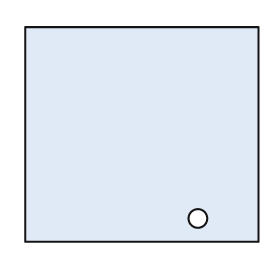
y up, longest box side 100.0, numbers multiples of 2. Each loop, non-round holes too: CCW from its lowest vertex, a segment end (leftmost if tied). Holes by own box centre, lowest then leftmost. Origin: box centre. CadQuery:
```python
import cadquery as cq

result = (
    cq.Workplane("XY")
    .moveTo(-50.0, -46.0)
    .lineTo(50.0, -46.0)
    .lineTo(50.0, 46.0)
    .lineTo(-50.0, 46.0)
    .close()
    .moveTo(24.0, -36.0)
    .circle(4.0)
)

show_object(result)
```